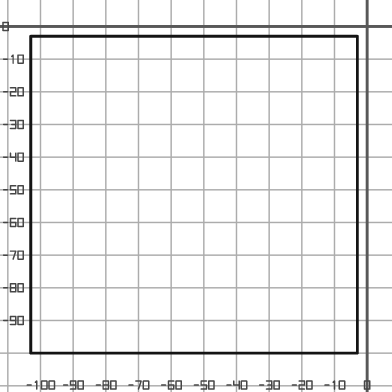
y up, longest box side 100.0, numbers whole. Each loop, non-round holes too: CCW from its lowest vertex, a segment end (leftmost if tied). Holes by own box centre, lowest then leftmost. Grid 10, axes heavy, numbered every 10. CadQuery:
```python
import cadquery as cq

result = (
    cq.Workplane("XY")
    .moveTo(-103.0, -100.0)
    .lineTo(-3.0, -100.0)
    .lineTo(-3.0, -3.0)
    .lineTo(-103.0, -3.0)
    .close()
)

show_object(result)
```